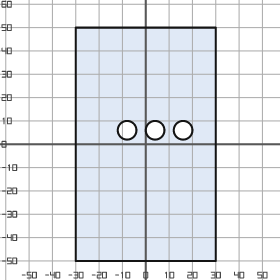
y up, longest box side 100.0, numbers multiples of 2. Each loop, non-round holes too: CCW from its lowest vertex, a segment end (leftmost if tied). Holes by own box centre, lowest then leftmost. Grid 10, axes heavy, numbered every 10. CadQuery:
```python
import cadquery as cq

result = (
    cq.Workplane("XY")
    .moveTo(-30.0, -50.0)
    .lineTo(30.0, -50.0)
    .lineTo(30.0, 50.0)
    .lineTo(-30.0, 50.0)
    .close()
    .moveTo(-8.0, 6.0)
    .circle(4.0)
    .moveTo(4.0, 6.0)
    .circle(4.0)
    .moveTo(16.0, 6.0)
    .circle(4.0)
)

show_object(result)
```